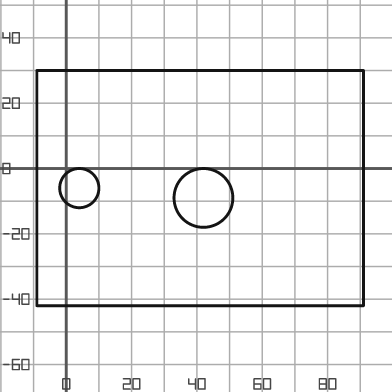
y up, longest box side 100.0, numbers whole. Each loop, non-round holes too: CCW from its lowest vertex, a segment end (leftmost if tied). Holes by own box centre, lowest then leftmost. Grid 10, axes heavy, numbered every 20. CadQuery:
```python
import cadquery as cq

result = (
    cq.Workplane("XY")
    .moveTo(-9.0, -42.0)
    .lineTo(91.0, -42.0)
    .lineTo(91.0, 30.0)
    .lineTo(-9.0, 30.0)
    .close()
    .moveTo(42.0, -9.0)
    .circle(9.0)
    .moveTo(4.0, -6.0)
    .circle(6.0)
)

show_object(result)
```